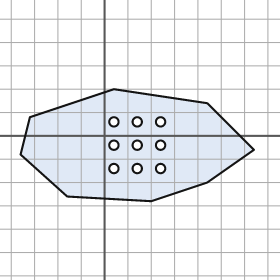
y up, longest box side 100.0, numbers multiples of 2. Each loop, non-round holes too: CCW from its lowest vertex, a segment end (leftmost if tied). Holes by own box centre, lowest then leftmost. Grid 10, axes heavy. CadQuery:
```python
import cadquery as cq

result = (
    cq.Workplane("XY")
    .moveTo(20.0, -28.0)
    .lineTo(44.0, -20.0)
    .lineTo(64.0, -6.0)
    .lineTo(44.0, 14.0)
    .lineTo(4.0, 20.0)
    .lineTo(-32.0, 8.0)
    .lineTo(-36.0, -8.0)
    .lineTo(-16.0, -26.0)
    .close()
    .moveTo(4.0, -14.0)
    .circle(2.0)
    .moveTo(14.0, -14.0)
    .circle(2.0)
    .moveTo(24.0, -14.0)
    .circle(2.0)
    .moveTo(4.0, -4.0)
    .circle(2.0)
    .moveTo(14.0, -4.0)
    .circle(2.0)
    .moveTo(24.0, -4.0)
    .circle(2.0)
    .moveTo(4.0, 6.0)
    .circle(2.0)
    .moveTo(14.0, 6.0)
    .circle(2.0)
    .moveTo(24.0, 6.0)
    .circle(2.0)
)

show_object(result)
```